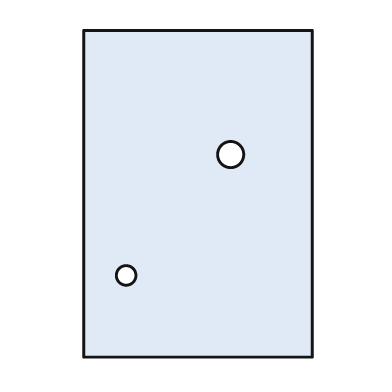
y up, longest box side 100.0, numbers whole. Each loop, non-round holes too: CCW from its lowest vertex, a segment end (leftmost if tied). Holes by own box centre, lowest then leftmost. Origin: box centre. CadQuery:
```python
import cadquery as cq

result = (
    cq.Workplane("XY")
    .moveTo(-35.0, -50.0)
    .lineTo(35.0, -50.0)
    .lineTo(35.0, 50.0)
    .lineTo(-35.0, 50.0)
    .close()
    .moveTo(-22.0, -25.0)
    .circle(3.0)
    .moveTo(10.0, 12.0)
    .circle(4.0)
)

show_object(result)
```